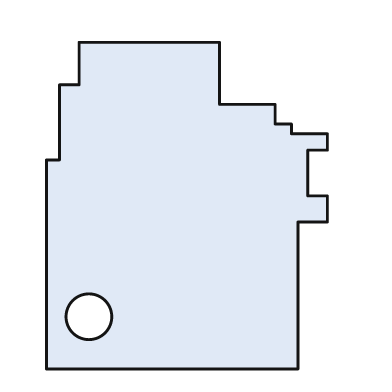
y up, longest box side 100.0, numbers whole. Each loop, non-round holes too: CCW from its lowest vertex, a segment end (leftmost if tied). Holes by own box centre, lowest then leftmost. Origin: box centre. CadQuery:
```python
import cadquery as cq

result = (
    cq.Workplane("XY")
    .moveTo(-43.0, -50.0)
    .lineTo(34.0, -50.0)
    .lineTo(34.0, -5.0)
    .lineTo(43.0, -5.0)
    .lineTo(43.0, 3.0)
    .lineTo(37.0, 3.0)
    .lineTo(37.0, 17.0)
    .lineTo(43.0, 17.0)
    .lineTo(43.0, 22.0)
    .lineTo(32.0, 22.0)
    .lineTo(32.0, 25.0)
    .lineTo(27.0, 25.0)
    .lineTo(27.0, 31.0)
    .lineTo(10.0, 31.0)
    .lineTo(10.0, 50.0)
    .lineTo(-33.0, 50.0)
    .lineTo(-33.0, 37.0)
    .lineTo(-39.0, 37.0)
    .lineTo(-39.0, 14.0)
    .lineTo(-43.0, 14.0)
    .close()
    .moveTo(-30.0, -34.0)
    .circle(7.0)
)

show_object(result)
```